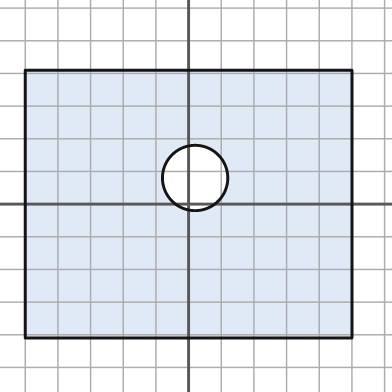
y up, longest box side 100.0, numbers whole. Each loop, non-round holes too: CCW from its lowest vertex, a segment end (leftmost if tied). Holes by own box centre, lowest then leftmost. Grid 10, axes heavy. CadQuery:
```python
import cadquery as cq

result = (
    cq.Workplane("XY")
    .moveTo(-50.0, -41.0)
    .lineTo(50.0, -41.0)
    .lineTo(50.0, 41.0)
    .lineTo(-50.0, 41.0)
    .close()
    .moveTo(2.0, 8.0)
    .circle(10.0)
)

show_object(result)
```